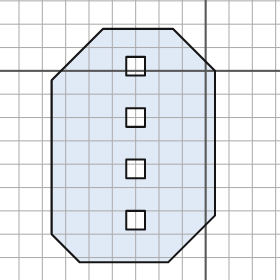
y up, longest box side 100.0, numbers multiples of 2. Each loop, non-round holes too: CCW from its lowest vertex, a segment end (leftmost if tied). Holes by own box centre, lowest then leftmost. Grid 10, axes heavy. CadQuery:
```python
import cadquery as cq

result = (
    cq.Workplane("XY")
    .moveTo(-54.0, -82.0)
    .lineTo(-16.0, -82.0)
    .lineTo(4.0, -62.0)
    .lineTo(4.0, 0.0)
    .lineTo(-14.0, 18.0)
    .lineTo(-44.0, 18.0)
    .lineTo(-66.0, -4.0)
    .lineTo(-66.0, -70.0)
    .close()
    .moveTo(-34.0, -68.0)
    .lineTo(-26.0, -68.0)
    .lineTo(-26.0, -60.0)
    .lineTo(-34.0, -60.0)
    .close()
    .moveTo(-34.0, -46.0)
    .lineTo(-26.0, -46.0)
    .lineTo(-26.0, -38.0)
    .lineTo(-34.0, -38.0)
    .close()
    .moveTo(-34.0, -24.0)
    .lineTo(-26.0, -24.0)
    .lineTo(-26.0, -16.0)
    .lineTo(-34.0, -16.0)
    .close()
    .moveTo(-34.0, -2.0)
    .lineTo(-26.0, -2.0)
    .lineTo(-26.0, 6.0)
    .lineTo(-34.0, 6.0)
    .close()
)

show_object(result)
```